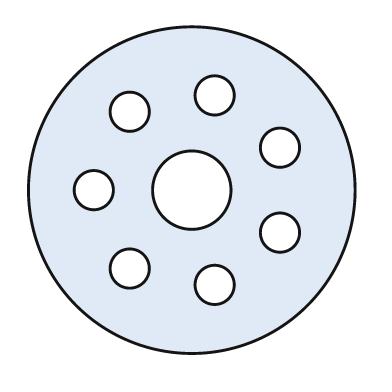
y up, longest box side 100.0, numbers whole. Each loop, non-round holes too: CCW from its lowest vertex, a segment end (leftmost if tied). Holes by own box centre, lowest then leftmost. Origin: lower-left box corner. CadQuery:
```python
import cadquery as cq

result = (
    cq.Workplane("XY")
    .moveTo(50.0, 50.0)
    .circle(50.0)
    .moveTo(57.0, 21.0)
    .circle(6.0)
    .moveTo(31.0, 26.0)
    .circle(6.0)
    .moveTo(77.0, 37.0)
    .circle(6.0)
    .moveTo(20.0, 50.0)
    .circle(6.0)
    .moveTo(50.0, 50.0)
    .circle(12.0)
    .moveTo(77.0, 63.0)
    .circle(6.0)
    .moveTo(31.0, 74.0)
    .circle(6.0)
    .moveTo(57.0, 79.0)
    .circle(6.0)
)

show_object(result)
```